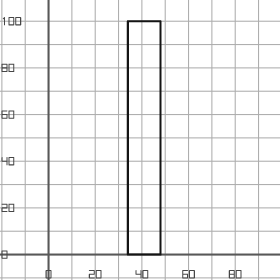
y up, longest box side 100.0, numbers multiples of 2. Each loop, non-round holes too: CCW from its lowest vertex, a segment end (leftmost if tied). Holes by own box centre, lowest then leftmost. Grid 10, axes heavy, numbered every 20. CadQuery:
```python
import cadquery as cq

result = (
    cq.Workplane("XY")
    .moveTo(34.0, 0.0)
    .lineTo(48.0, 0.0)
    .lineTo(48.0, 100.0)
    .lineTo(34.0, 100.0)
    .close()
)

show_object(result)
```